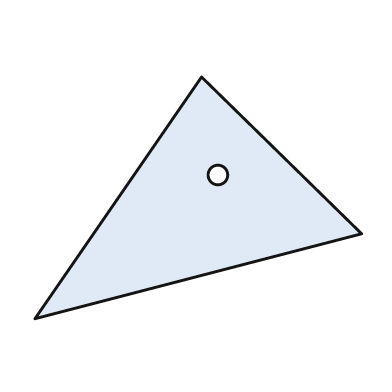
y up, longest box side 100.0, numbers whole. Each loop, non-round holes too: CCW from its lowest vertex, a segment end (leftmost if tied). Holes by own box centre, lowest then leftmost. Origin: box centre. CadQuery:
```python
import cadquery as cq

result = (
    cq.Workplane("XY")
    .moveTo(-50.0, -37.0)
    .lineTo(50.0, -11.0)
    .lineTo(1.0, 37.0)
    .close()
    .moveTo(6.0, 7.0)
    .circle(3.0)
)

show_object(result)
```